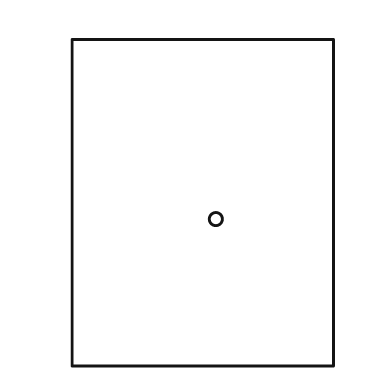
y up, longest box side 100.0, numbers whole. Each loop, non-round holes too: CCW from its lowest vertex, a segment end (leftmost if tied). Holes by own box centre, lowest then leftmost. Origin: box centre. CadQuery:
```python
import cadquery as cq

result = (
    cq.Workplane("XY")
    .moveTo(-40.0, -50.0)
    .lineTo(40.0, -50.0)
    .lineTo(40.0, 50.0)
    .lineTo(-40.0, 50.0)
    .close()
    .moveTo(4.0, -5.0)
    .circle(2.0)
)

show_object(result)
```